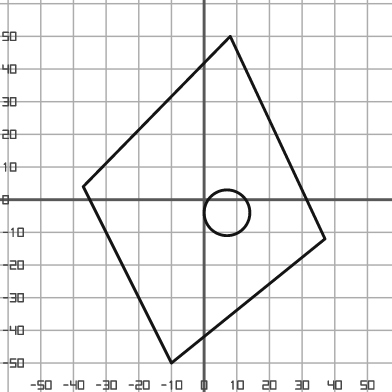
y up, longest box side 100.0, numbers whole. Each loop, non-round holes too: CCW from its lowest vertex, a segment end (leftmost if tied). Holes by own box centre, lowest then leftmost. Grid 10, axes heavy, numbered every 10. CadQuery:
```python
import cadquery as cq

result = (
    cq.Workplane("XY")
    .moveTo(-10.0, -50.0)
    .lineTo(37.0, -12.0)
    .lineTo(8.0, 50.0)
    .lineTo(-37.0, 4.0)
    .close()
    .moveTo(7.0, -4.0)
    .circle(7.0)
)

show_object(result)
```